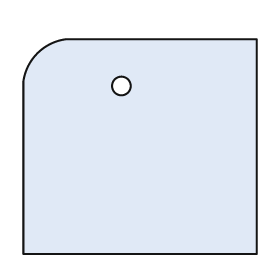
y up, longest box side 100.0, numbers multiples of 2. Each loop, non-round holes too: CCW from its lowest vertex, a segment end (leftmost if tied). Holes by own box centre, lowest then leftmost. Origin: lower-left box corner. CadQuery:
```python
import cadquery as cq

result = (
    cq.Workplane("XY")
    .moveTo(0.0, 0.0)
    .lineTo(100.0, 0.0)
    .lineTo(100.0, 92.0)
    .lineTo(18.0, 92.0)
    .threePointArc((6.0, 86.0), (0.0, 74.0))
    .close()
    .moveTo(42.0, 72.0)
    .circle(4.0)
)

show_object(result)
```